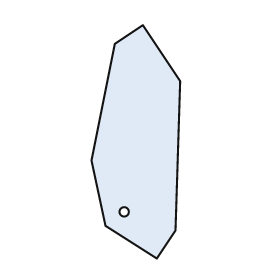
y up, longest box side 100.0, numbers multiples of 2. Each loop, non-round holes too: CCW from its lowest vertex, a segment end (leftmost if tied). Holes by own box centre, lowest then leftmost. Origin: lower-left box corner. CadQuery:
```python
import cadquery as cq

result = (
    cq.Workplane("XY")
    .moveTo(28.0, 0.0)
    .lineTo(36.0, 12.0)
    .lineTo(38.0, 76.0)
    .lineTo(22.0, 100.0)
    .lineTo(10.0, 92.0)
    .lineTo(0.0, 42.0)
    .lineTo(6.0, 14.0)
    .close()
    .moveTo(14.0, 20.0)
    .circle(2.0)
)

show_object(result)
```